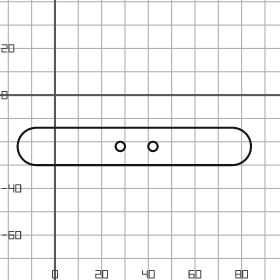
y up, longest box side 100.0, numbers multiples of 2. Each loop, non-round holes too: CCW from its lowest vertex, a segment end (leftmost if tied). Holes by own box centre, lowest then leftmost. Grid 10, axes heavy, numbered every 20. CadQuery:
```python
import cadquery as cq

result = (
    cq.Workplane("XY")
    .moveTo(-8.0, -30.0)
    .lineTo(76.0, -30.0)
    .threePointArc((84.0, -22.0), (76.0, -14.0))
    .lineTo(-8.0, -14.0)
    .threePointArc((-16.0, -22.0), (-8.0, -30.0))
    .close()
    .moveTo(28.0, -22.0)
    .circle(2.0)
    .moveTo(42.0, -22.0)
    .circle(2.0)
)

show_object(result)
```